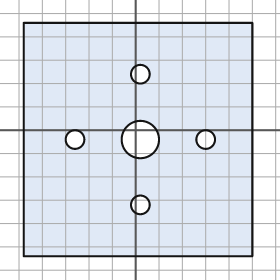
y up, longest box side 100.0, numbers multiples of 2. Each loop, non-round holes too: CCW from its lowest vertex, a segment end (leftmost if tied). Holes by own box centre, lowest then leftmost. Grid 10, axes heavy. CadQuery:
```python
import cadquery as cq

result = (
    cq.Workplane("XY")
    .moveTo(-48.0, -54.0)
    .lineTo(50.0, -54.0)
    .lineTo(50.0, 46.0)
    .lineTo(-48.0, 46.0)
    .close()
    .moveTo(2.0, -32.0)
    .circle(4.0)
    .moveTo(-26.0, -4.0)
    .circle(4.0)
    .moveTo(2.0, -4.0)
    .circle(8.0)
    .moveTo(30.0, -4.0)
    .circle(4.0)
    .moveTo(2.0, 24.0)
    .circle(4.0)
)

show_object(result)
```